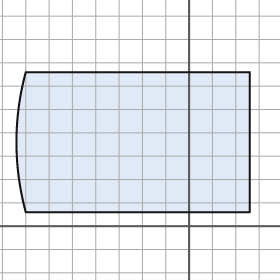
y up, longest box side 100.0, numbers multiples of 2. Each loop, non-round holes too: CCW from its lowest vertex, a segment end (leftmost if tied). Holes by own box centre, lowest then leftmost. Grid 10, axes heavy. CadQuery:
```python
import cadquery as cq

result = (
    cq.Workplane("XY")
    .moveTo(-70.0, 6.0)
    .lineTo(26.0, 6.0)
    .lineTo(26.0, 66.0)
    .lineTo(-70.0, 66.0)
    .threePointArc((-74.0, 36.0), (-70.0, 6.0))
    .close()
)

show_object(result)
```